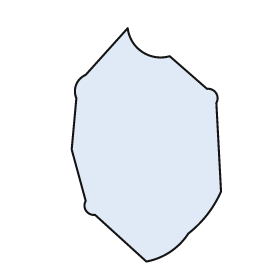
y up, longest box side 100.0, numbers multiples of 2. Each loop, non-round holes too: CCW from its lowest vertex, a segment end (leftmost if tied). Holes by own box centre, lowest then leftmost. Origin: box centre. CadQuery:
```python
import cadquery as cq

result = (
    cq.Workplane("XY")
    .moveTo(0.0, -50.0)
    .threePointArc((10.0, -46.0), (18.0, -38.0))
    .threePointArc((26.0, -30.0), (32.0, -20.0))
    .lineTo(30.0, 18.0)
    .threePointArc((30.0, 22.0), (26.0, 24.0))
    .lineTo(10.0, 38.0)
    .threePointArc((-2.0, 40.0), (-8.0, 50.0))
    .lineTo(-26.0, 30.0)
    .threePointArc((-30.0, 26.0), (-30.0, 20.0))
    .lineTo(-32.0, -2.0)
    .lineTo(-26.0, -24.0)
    .threePointArc((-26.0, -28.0), (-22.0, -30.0))
    .close()
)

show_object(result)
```